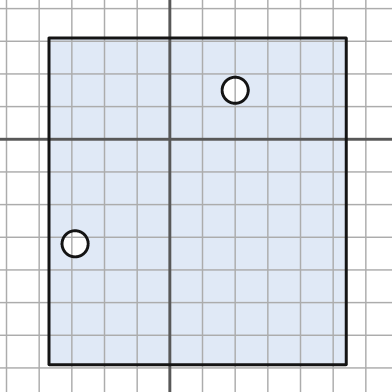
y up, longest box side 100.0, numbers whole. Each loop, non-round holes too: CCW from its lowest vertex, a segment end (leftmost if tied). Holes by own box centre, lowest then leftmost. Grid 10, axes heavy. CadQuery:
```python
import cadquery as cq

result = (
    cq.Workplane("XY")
    .moveTo(-37.0, -69.0)
    .lineTo(54.0, -69.0)
    .lineTo(54.0, 31.0)
    .lineTo(-37.0, 31.0)
    .close()
    .moveTo(-29.0, -32.0)
    .circle(4.0)
    .moveTo(20.0, 15.0)
    .circle(4.0)
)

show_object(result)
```